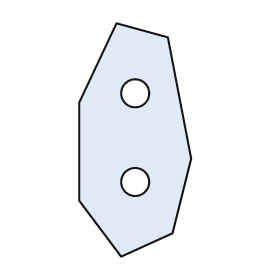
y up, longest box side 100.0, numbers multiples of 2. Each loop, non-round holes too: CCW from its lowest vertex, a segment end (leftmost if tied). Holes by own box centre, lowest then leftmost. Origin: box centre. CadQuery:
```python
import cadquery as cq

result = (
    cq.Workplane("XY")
    .moveTo(-6.0, -50.0)
    .lineTo(16.0, -40.0)
    .lineTo(24.0, -8.0)
    .lineTo(14.0, 44.0)
    .lineTo(-8.0, 50.0)
    .lineTo(-24.0, 16.0)
    .lineTo(-24.0, -26.0)
    .close()
    .moveTo(0.0, -18.0)
    .circle(6.0)
    .moveTo(0.0, 20.0)
    .circle(6.0)
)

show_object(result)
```